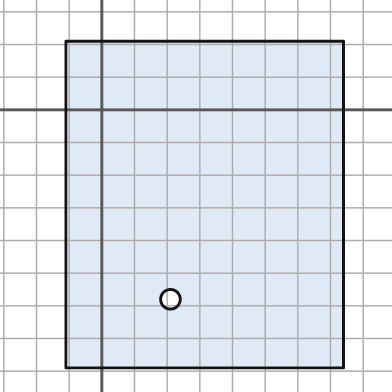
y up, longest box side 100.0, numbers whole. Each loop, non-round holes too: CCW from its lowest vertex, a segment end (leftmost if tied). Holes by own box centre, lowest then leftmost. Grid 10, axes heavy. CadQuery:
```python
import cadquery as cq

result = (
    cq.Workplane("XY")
    .moveTo(-11.0, -79.0)
    .lineTo(74.0, -79.0)
    .lineTo(74.0, 21.0)
    .lineTo(-11.0, 21.0)
    .close()
    .moveTo(21.0, -58.0)
    .circle(3.0)
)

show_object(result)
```